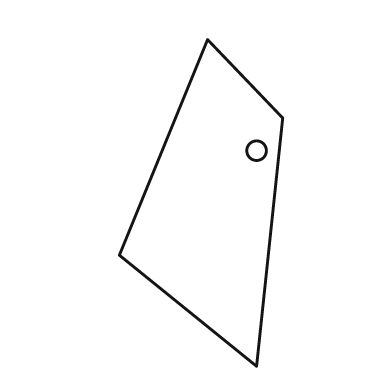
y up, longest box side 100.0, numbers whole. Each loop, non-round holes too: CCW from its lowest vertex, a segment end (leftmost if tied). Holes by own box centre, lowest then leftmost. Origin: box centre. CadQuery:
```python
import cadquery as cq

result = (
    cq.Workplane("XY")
    .moveTo(17.0, -50.0)
    .lineTo(25.0, 26.0)
    .lineTo(2.0, 50.0)
    .lineTo(-25.0, -16.0)
    .close()
    .moveTo(17.0, 16.0)
    .circle(3.0)
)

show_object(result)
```